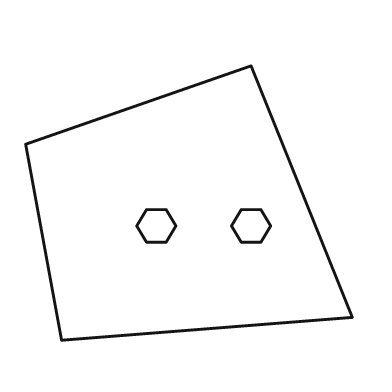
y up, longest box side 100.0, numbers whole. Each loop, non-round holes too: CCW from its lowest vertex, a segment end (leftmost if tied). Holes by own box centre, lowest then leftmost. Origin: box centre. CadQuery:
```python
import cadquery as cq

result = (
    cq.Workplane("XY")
    .moveTo(-39.0, -42.0)
    .lineTo(50.0, -35.0)
    .lineTo(19.0, 42.0)
    .lineTo(-50.0, 18.0)
    .close()
    .moveTo(-13.0, -12.0)
    .lineTo(-7.0, -12.0)
    .lineTo(-4.0, -7.0)
    .lineTo(-7.0, -2.0)
    .lineTo(-13.0, -2.0)
    .lineTo(-16.0, -7.0)
    .close()
    .moveTo(16.0, -12.0)
    .lineTo(22.0, -12.0)
    .lineTo(25.0, -7.0)
    .lineTo(22.0, -2.0)
    .lineTo(16.0, -2.0)
    .lineTo(13.0, -7.0)
    .close()
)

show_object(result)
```